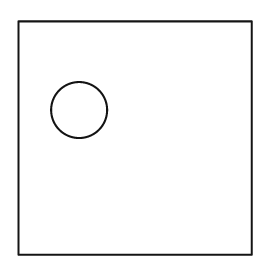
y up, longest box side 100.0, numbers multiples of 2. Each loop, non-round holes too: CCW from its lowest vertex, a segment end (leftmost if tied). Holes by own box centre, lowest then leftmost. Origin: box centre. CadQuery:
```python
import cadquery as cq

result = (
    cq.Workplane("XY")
    .moveTo(-50.0, -50.0)
    .lineTo(50.0, -50.0)
    .lineTo(50.0, 50.0)
    .lineTo(-50.0, 50.0)
    .close()
    .moveTo(-24.0, 12.0)
    .circle(12.0)
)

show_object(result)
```